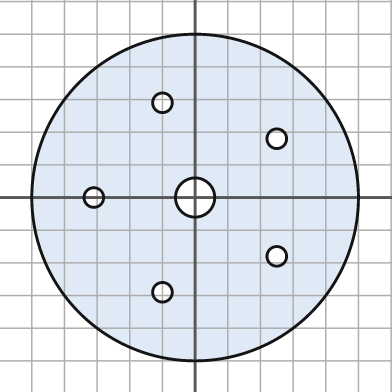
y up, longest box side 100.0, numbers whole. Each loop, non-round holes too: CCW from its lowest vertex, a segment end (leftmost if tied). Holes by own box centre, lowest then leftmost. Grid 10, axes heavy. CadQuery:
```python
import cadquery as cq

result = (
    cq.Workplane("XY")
    .moveTo(0.0, 0.0)
    .circle(50.0)
    .moveTo(-10.0, -29.0)
    .circle(3.0)
    .moveTo(25.0, -18.0)
    .circle(3.0)
    .moveTo(-31.0, 0.0)
    .circle(3.0)
    .moveTo(0.0, 0.0)
    .circle(6.0)
    .moveTo(25.0, 18.0)
    .circle(3.0)
    .moveTo(-10.0, 29.0)
    .circle(3.0)
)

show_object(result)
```